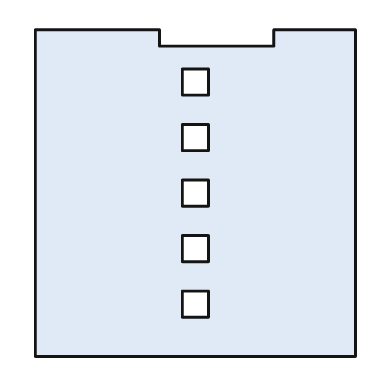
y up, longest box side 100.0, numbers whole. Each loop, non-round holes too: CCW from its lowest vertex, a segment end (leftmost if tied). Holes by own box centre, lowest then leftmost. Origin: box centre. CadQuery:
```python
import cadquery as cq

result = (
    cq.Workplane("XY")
    .moveTo(-49.0, -50.0)
    .lineTo(49.0, -50.0)
    .lineTo(49.0, 50.0)
    .lineTo(24.0, 50.0)
    .lineTo(24.0, 45.0)
    .lineTo(-11.0, 45.0)
    .lineTo(-11.0, 50.0)
    .lineTo(-49.0, 50.0)
    .close()
    .moveTo(-4.0, -38.0)
    .lineTo(4.0, -38.0)
    .lineTo(4.0, -30.0)
    .lineTo(-4.0, -30.0)
    .close()
    .moveTo(-4.0, -21.0)
    .lineTo(4.0, -21.0)
    .lineTo(4.0, -13.0)
    .lineTo(-4.0, -13.0)
    .close()
    .moveTo(-4.0, -4.0)
    .lineTo(4.0, -4.0)
    .lineTo(4.0, 4.0)
    .lineTo(-4.0, 4.0)
    .close()
    .moveTo(-4.0, 13.0)
    .lineTo(4.0, 13.0)
    .lineTo(4.0, 21.0)
    .lineTo(-4.0, 21.0)
    .close()
    .moveTo(-4.0, 30.0)
    .lineTo(4.0, 30.0)
    .lineTo(4.0, 38.0)
    .lineTo(-4.0, 38.0)
    .close()
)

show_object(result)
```